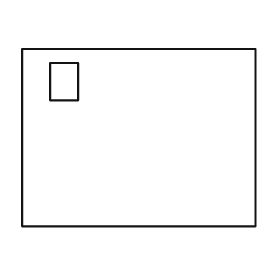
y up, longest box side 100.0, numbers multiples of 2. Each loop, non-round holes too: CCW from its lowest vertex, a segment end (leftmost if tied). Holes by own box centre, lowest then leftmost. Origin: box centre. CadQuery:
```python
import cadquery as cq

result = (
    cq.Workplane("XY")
    .moveTo(-50.0, -38.0)
    .lineTo(50.0, -38.0)
    .lineTo(50.0, 38.0)
    .lineTo(-50.0, 38.0)
    .close()
    .moveTo(-38.0, 16.0)
    .lineTo(-26.0, 16.0)
    .lineTo(-26.0, 32.0)
    .lineTo(-38.0, 32.0)
    .close()
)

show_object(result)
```